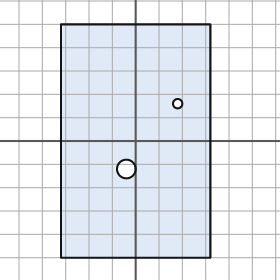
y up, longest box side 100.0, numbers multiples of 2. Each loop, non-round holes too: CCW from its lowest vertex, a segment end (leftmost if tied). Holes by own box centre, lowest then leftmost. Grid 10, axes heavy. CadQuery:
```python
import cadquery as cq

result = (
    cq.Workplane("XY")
    .moveTo(-32.0, -50.0)
    .lineTo(32.0, -50.0)
    .lineTo(32.0, 50.0)
    .lineTo(-32.0, 50.0)
    .close()
    .moveTo(-4.0, -12.0)
    .circle(4.0)
    .moveTo(18.0, 16.0)
    .circle(2.0)
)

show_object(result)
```